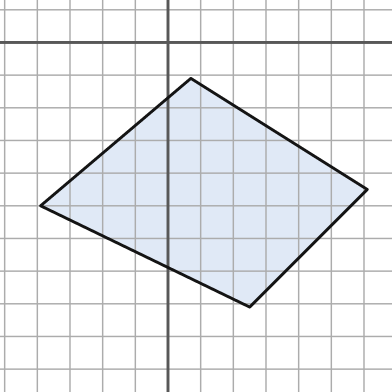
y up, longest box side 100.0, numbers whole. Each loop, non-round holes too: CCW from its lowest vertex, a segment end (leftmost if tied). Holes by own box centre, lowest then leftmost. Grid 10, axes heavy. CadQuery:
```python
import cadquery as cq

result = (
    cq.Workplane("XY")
    .moveTo(25.0, -81.0)
    .lineTo(61.0, -45.0)
    .lineTo(7.0, -11.0)
    .lineTo(-39.0, -50.0)
    .close()
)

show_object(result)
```